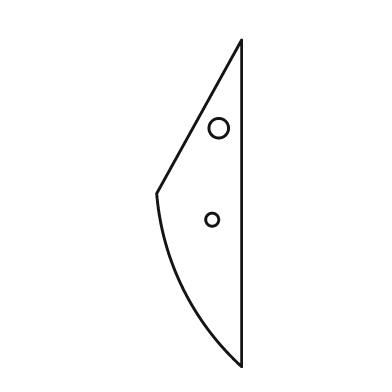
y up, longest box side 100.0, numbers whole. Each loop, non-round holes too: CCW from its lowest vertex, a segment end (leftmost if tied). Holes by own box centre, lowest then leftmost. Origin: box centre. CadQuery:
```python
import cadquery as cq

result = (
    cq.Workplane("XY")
    .moveTo(13.0, -50.0)
    .lineTo(13.0, 50.0)
    .lineTo(-13.0, 3.0)
    .threePointArc((-5.0, -26.0), (13.0, -50.0))
    .close()
    .moveTo(4.0, -5.0)
    .circle(2.0)
    .moveTo(6.0, 23.0)
    .circle(3.0)
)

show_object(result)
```